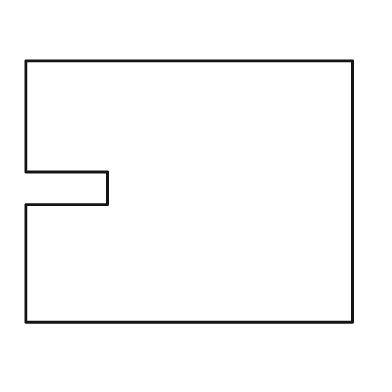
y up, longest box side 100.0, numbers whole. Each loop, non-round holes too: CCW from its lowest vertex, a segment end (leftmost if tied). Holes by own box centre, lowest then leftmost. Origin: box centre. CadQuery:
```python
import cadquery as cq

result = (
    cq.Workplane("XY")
    .moveTo(-50.0, -40.0)
    .lineTo(50.0, -40.0)
    .lineTo(50.0, 40.0)
    .lineTo(-50.0, 40.0)
    .lineTo(-50.0, 6.0)
    .lineTo(-25.0, 6.0)
    .lineTo(-25.0, -4.0)
    .lineTo(-50.0, -4.0)
    .close()
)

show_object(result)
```